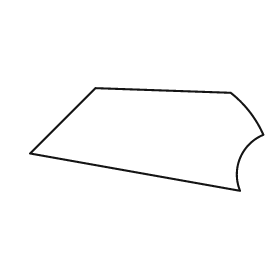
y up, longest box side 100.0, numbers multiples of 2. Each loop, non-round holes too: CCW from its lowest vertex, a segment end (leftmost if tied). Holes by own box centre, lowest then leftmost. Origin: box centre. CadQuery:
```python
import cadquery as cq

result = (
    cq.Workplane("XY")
    .moveTo(40.0, -22.0)
    .threePointArc((40.0, -8.0), (50.0, 2.0))
    .threePointArc((44.0, 12.0), (36.0, 20.0))
    .lineTo(-22.0, 22.0)
    .lineTo(-50.0, -6.0)
    .close()
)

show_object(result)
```